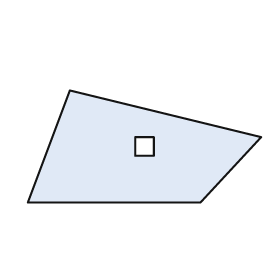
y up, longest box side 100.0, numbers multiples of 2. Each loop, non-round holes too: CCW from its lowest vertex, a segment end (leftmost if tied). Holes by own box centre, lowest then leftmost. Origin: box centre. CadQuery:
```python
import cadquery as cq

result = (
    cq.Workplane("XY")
    .moveTo(-50.0, -24.0)
    .lineTo(24.0, -24.0)
    .lineTo(50.0, 4.0)
    .lineTo(-32.0, 24.0)
    .close()
    .moveTo(-4.0, -4.0)
    .lineTo(4.0, -4.0)
    .lineTo(4.0, 4.0)
    .lineTo(-4.0, 4.0)
    .close()
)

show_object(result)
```